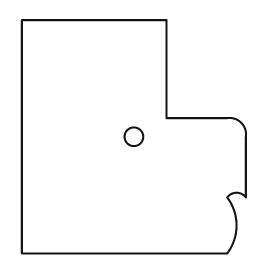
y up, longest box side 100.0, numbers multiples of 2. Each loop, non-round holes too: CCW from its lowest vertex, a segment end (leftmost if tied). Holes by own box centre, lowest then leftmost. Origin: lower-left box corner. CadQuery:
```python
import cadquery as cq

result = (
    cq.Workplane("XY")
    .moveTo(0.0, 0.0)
    .lineTo(88.0, 0.0)
    .threePointArc((92.0, 12.0), (88.0, 24.0))
    .threePointArc((92.0, 26.0), (96.0, 24.0))
    .lineTo(96.0, 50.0)
    .threePointArc((94.0, 56.0), (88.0, 58.0))
    .lineTo(62.0, 58.0)
    .lineTo(62.0, 100.0)
    .lineTo(0.0, 100.0)
    .close()
    .moveTo(48.0, 50.0)
    .circle(4.0)
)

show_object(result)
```